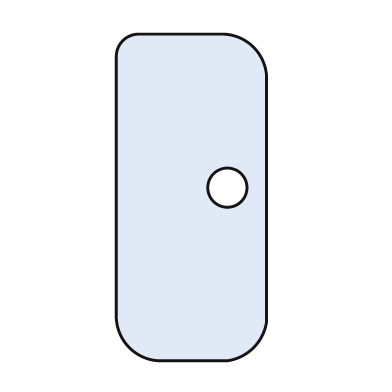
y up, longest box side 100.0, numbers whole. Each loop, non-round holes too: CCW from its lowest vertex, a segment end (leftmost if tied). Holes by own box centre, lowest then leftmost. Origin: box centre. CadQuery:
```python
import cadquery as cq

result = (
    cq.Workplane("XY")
    .moveTo(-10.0, -50.0)
    .lineTo(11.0, -50.0)
    .threePointArc((19.0, -46.0), (23.0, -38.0))
    .lineTo(23.0, 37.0)
    .threePointArc((19.0, 46.0), (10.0, 50.0))
    .lineTo(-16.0, 50.0)
    .threePointArc((-21.0, 48.0), (-23.0, 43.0))
    .lineTo(-23.0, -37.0)
    .threePointArc((-19.0, -46.0), (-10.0, -50.0))
    .close()
    .moveTo(11.0, 3.0)
    .circle(6.0)
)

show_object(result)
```